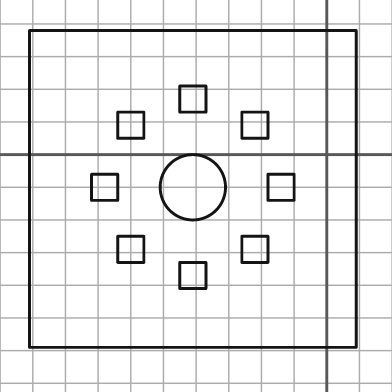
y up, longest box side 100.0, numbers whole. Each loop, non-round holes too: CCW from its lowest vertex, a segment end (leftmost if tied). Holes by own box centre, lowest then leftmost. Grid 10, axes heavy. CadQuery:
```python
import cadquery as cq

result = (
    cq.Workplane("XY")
    .moveTo(-91.0, -59.0)
    .lineTo(9.0, -59.0)
    .lineTo(9.0, 38.0)
    .lineTo(-91.0, 38.0)
    .close()
    .moveTo(-45.0, -41.0)
    .lineTo(-37.0, -41.0)
    .lineTo(-37.0, -33.0)
    .lineTo(-45.0, -33.0)
    .close()
    .moveTo(-64.0, -33.0)
    .lineTo(-56.0, -33.0)
    .lineTo(-56.0, -25.0)
    .lineTo(-64.0, -25.0)
    .close()
    .moveTo(-26.0, -33.0)
    .lineTo(-18.0, -33.0)
    .lineTo(-18.0, -25.0)
    .lineTo(-26.0, -25.0)
    .close()
    .moveTo(-72.0, -14.0)
    .lineTo(-64.0, -14.0)
    .lineTo(-64.0, -6.0)
    .lineTo(-72.0, -6.0)
    .close()
    .moveTo(-41.0, -10.0)
    .circle(10.0)
    .moveTo(-18.0, -14.0)
    .lineTo(-10.0, -14.0)
    .lineTo(-10.0, -6.0)
    .lineTo(-18.0, -6.0)
    .close()
    .moveTo(-64.0, 5.0)
    .lineTo(-56.0, 5.0)
    .lineTo(-56.0, 13.0)
    .lineTo(-64.0, 13.0)
    .close()
    .moveTo(-26.0, 5.0)
    .lineTo(-18.0, 5.0)
    .lineTo(-18.0, 13.0)
    .lineTo(-26.0, 13.0)
    .close()
    .moveTo(-45.0, 13.0)
    .lineTo(-37.0, 13.0)
    .lineTo(-37.0, 21.0)
    .lineTo(-45.0, 21.0)
    .close()
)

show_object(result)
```